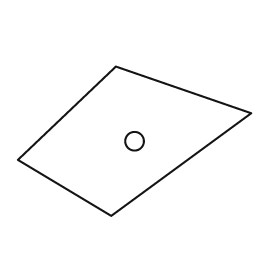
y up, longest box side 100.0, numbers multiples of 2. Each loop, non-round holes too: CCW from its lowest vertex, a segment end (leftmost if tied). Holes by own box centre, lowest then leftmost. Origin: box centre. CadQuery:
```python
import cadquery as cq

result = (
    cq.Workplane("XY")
    .moveTo(-10.0, -32.0)
    .lineTo(50.0, 12.0)
    .lineTo(-8.0, 32.0)
    .lineTo(-50.0, -8.0)
    .close()
    .moveTo(0.0, 0.0)
    .circle(4.0)
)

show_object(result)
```